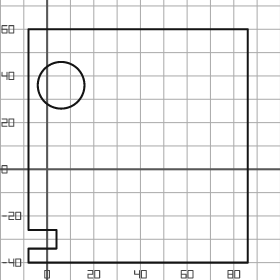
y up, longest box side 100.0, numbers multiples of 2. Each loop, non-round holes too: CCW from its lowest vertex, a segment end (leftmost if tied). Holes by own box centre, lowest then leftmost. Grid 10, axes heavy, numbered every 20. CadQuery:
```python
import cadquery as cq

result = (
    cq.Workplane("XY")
    .moveTo(-8.0, -40.0)
    .lineTo(86.0, -40.0)
    .lineTo(86.0, 60.0)
    .lineTo(-8.0, 60.0)
    .lineTo(-8.0, -26.0)
    .lineTo(4.0, -26.0)
    .lineTo(4.0, -34.0)
    .lineTo(-8.0, -34.0)
    .close()
    .moveTo(6.0, 36.0)
    .circle(10.0)
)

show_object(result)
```